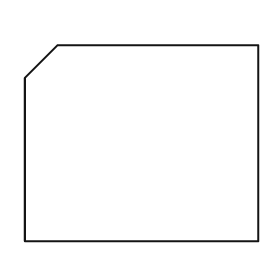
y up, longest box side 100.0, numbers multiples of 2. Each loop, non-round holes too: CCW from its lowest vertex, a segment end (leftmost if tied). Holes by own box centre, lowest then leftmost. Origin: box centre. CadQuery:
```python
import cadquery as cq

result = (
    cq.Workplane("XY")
    .moveTo(-50.0, -42.0)
    .lineTo(50.0, -42.0)
    .lineTo(50.0, 42.0)
    .lineTo(-36.0, 42.0)
    .lineTo(-50.0, 28.0)
    .close()
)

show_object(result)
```